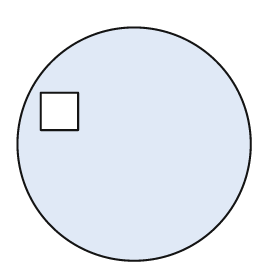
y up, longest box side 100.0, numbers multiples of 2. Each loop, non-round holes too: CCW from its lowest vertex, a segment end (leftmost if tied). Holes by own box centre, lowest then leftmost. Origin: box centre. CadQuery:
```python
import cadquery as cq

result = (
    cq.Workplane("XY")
    .moveTo(0.0, 0.0)
    .circle(50.0)
    .moveTo(-40.0, 6.0)
    .lineTo(-24.0, 6.0)
    .lineTo(-24.0, 22.0)
    .lineTo(-40.0, 22.0)
    .close()
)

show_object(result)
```